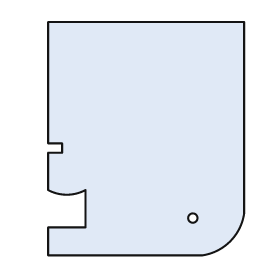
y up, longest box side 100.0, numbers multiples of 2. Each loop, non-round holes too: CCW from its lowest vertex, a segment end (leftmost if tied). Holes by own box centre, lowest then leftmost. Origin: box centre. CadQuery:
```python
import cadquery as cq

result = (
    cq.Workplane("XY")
    .moveTo(-42.0, -50.0)
    .lineTo(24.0, -50.0)
    .threePointArc((36.0, -44.0), (42.0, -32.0))
    .lineTo(42.0, 50.0)
    .lineTo(-42.0, 50.0)
    .lineTo(-42.0, -2.0)
    .lineTo(-36.0, -2.0)
    .lineTo(-36.0, -6.0)
    .lineTo(-42.0, -6.0)
    .lineTo(-42.0, -22.0)
    .threePointArc((-34.0, -24.0), (-26.0, -22.0))
    .lineTo(-26.0, -38.0)
    .lineTo(-42.0, -38.0)
    .close()
    .moveTo(20.0, -34.0)
    .circle(2.0)
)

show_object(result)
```